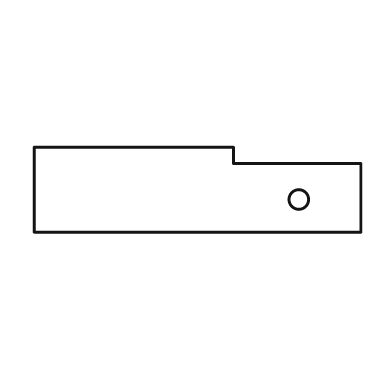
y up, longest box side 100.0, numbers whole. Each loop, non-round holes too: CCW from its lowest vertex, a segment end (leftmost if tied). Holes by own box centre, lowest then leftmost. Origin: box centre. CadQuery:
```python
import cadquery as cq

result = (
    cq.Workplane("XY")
    .moveTo(-50.0, -13.0)
    .lineTo(50.0, -13.0)
    .lineTo(50.0, 8.0)
    .lineTo(11.0, 8.0)
    .lineTo(11.0, 13.0)
    .lineTo(-50.0, 13.0)
    .close()
    .moveTo(31.0, -3.0)
    .circle(3.0)
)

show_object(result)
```